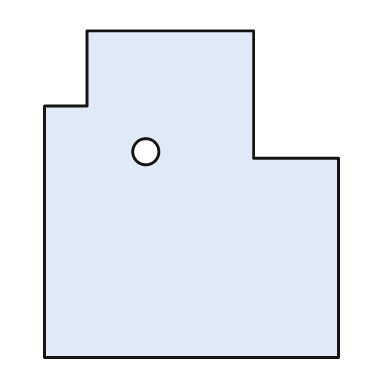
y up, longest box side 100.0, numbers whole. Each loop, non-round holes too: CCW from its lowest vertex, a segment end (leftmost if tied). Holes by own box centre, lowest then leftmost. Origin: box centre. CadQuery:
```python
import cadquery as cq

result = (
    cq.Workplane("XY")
    .moveTo(-45.0, -50.0)
    .lineTo(45.0, -50.0)
    .lineTo(45.0, 11.0)
    .lineTo(19.0, 11.0)
    .lineTo(19.0, 50.0)
    .lineTo(-32.0, 50.0)
    .lineTo(-32.0, 27.0)
    .lineTo(-45.0, 27.0)
    .close()
    .moveTo(-14.0, 13.0)
    .circle(4.0)
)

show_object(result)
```